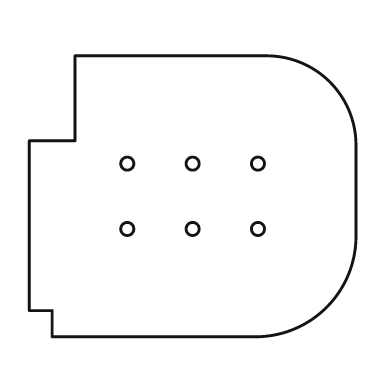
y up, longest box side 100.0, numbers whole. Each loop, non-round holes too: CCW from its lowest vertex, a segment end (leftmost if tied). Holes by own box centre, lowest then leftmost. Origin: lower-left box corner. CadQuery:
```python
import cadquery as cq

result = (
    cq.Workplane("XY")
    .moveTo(7.0, 0.0)
    .lineTo(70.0, 0.0)
    .threePointArc((91.0, 9.0), (100.0, 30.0))
    .lineTo(100.0, 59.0)
    .threePointArc((92.0, 78.0), (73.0, 86.0))
    .lineTo(14.0, 86.0)
    .lineTo(14.0, 60.0)
    .lineTo(0.0, 60.0)
    .lineTo(0.0, 8.0)
    .lineTo(7.0, 8.0)
    .close()
    .moveTo(30.0, 33.0)
    .circle(2.0)
    .moveTo(50.0, 33.0)
    .circle(2.0)
    .moveTo(70.0, 33.0)
    .circle(2.0)
    .moveTo(30.0, 53.0)
    .circle(2.0)
    .moveTo(50.0, 53.0)
    .circle(2.0)
    .moveTo(70.0, 53.0)
    .circle(2.0)
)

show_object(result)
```